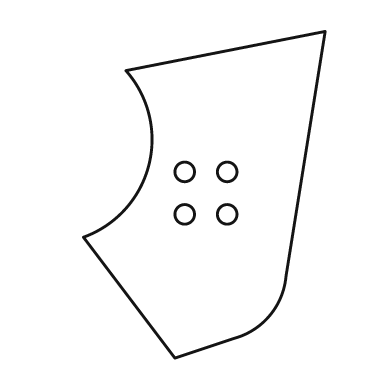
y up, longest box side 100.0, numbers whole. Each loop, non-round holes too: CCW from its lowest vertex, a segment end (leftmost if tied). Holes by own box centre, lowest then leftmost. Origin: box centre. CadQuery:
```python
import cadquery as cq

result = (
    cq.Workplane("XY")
    .moveTo(-9.0, -50.0)
    .lineTo(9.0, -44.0)
    .threePointArc((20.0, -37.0), (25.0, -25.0))
    .lineTo(37.0, 50.0)
    .lineTo(-24.0, 38.0)
    .threePointArc((-17.0, 9.0), (-37.0, -13.0))
    .close()
    .moveTo(-6.0, -6.0)
    .circle(3.0)
    .moveTo(7.0, -6.0)
    .circle(3.0)
    .moveTo(-6.0, 7.0)
    .circle(3.0)
    .moveTo(7.0, 7.0)
    .circle(3.0)
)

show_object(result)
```